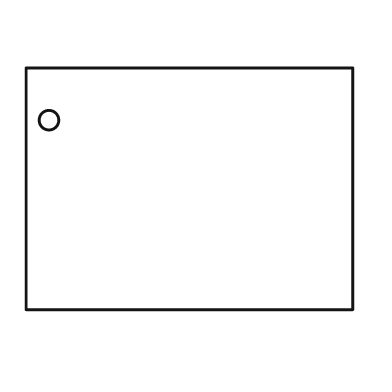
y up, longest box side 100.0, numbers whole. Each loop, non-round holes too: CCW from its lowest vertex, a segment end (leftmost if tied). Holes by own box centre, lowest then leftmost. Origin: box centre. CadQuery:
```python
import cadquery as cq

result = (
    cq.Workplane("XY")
    .moveTo(-50.0, -37.0)
    .lineTo(50.0, -37.0)
    .lineTo(50.0, 37.0)
    .lineTo(-50.0, 37.0)
    .close()
    .moveTo(-43.0, 21.0)
    .circle(3.0)
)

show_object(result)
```